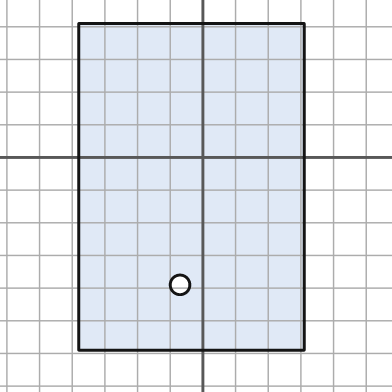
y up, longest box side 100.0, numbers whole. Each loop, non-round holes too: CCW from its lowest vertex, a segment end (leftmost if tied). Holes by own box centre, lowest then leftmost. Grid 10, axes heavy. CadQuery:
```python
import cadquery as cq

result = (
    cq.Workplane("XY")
    .moveTo(-38.0, -59.0)
    .lineTo(31.0, -59.0)
    .lineTo(31.0, 41.0)
    .lineTo(-38.0, 41.0)
    .close()
    .moveTo(-7.0, -39.0)
    .circle(3.0)
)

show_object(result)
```